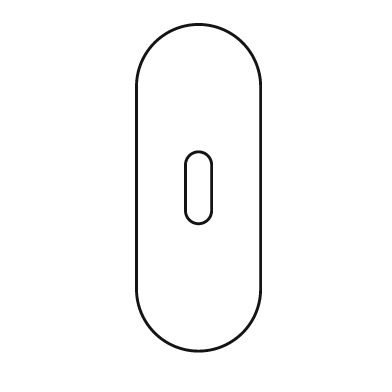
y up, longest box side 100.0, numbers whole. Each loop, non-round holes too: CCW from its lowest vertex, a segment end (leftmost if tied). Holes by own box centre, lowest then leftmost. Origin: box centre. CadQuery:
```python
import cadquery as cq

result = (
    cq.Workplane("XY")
    .moveTo(-19.0, -31.0)
    .threePointArc((0.0, -50.0), (19.0, -31.0))
    .lineTo(19.0, 31.0)
    .threePointArc((0.0, 50.0), (-19.0, 31.0))
    .close()
    .moveTo(-4.0, -7.0)
    .threePointArc((0.0, -11.0), (4.0, -7.0))
    .lineTo(4.0, 7.0)
    .threePointArc((0.0, 11.0), (-4.0, 7.0))
    .close()
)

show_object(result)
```